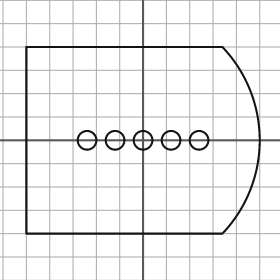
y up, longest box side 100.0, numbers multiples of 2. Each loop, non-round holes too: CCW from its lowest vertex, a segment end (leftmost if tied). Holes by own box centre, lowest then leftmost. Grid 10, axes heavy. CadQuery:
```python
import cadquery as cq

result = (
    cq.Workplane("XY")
    .moveTo(-50.0, -40.0)
    .lineTo(34.0, -40.0)
    .threePointArc((50.0, 0.0), (34.0, 40.0))
    .lineTo(-50.0, 40.0)
    .close()
    .moveTo(-24.0, 0.0)
    .circle(4.0)
    .moveTo(-12.0, 0.0)
    .circle(4.0)
    .moveTo(0.0, 0.0)
    .circle(4.0)
    .moveTo(12.0, 0.0)
    .circle(4.0)
    .moveTo(24.0, 0.0)
    .circle(4.0)
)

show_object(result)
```